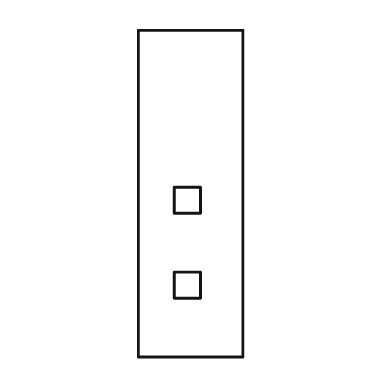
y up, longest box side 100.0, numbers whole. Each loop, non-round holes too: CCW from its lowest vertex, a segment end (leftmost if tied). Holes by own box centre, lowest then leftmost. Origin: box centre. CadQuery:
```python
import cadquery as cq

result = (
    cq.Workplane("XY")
    .moveTo(-16.0, -50.0)
    .lineTo(16.0, -50.0)
    .lineTo(16.0, 50.0)
    .lineTo(-16.0, 50.0)
    .close()
    .moveTo(-5.0, -32.0)
    .lineTo(3.0, -32.0)
    .lineTo(3.0, -24.0)
    .lineTo(-5.0, -24.0)
    .close()
    .moveTo(-5.0, -6.0)
    .lineTo(3.0, -6.0)
    .lineTo(3.0, 2.0)
    .lineTo(-5.0, 2.0)
    .close()
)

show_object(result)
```